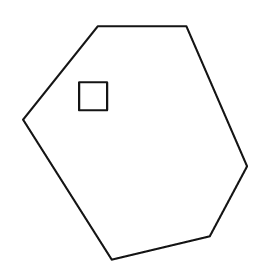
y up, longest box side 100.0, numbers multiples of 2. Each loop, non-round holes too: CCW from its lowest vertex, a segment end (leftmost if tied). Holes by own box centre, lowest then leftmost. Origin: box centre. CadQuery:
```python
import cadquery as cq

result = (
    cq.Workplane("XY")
    .moveTo(-10.0, -50.0)
    .lineTo(32.0, -40.0)
    .lineTo(48.0, -10.0)
    .lineTo(22.0, 50.0)
    .lineTo(-16.0, 50.0)
    .lineTo(-48.0, 10.0)
    .close()
    .moveTo(-24.0, 14.0)
    .lineTo(-12.0, 14.0)
    .lineTo(-12.0, 26.0)
    .lineTo(-24.0, 26.0)
    .close()
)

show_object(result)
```